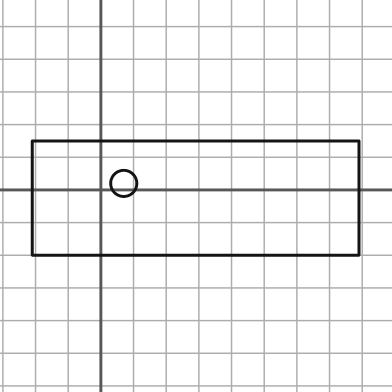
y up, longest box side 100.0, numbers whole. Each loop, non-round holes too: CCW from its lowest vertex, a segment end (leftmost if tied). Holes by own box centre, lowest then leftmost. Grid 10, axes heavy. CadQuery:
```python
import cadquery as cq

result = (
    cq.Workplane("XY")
    .moveTo(-21.0, -20.0)
    .lineTo(79.0, -20.0)
    .lineTo(79.0, 15.0)
    .lineTo(-21.0, 15.0)
    .close()
    .moveTo(7.0, 2.0)
    .circle(4.0)
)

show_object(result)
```